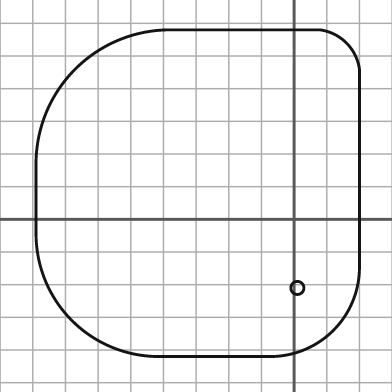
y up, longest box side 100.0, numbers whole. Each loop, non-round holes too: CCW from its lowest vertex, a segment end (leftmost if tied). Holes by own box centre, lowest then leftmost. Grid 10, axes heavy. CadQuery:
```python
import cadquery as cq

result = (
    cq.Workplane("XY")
    .moveTo(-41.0, -42.0)
    .lineTo(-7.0, -42.0)
    .threePointArc((12.0, -34.0), (20.0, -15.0))
    .lineTo(20.0, 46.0)
    .threePointArc((16.0, 54.0), (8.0, 58.0))
    .lineTo(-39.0, 58.0)
    .threePointArc((-67.0, 46.0), (-79.0, 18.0))
    .lineTo(-79.0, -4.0)
    .threePointArc((-68.0, -31.0), (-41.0, -42.0))
    .close()
    .moveTo(1.0, -21.0)
    .circle(2.0)
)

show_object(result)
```